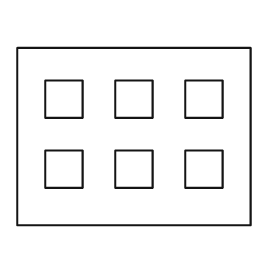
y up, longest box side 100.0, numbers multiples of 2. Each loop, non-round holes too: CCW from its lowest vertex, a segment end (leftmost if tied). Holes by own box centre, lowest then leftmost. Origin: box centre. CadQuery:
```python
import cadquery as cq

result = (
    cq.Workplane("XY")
    .moveTo(-50.0, -38.0)
    .lineTo(50.0, -38.0)
    .lineTo(50.0, 38.0)
    .lineTo(-50.0, 38.0)
    .close()
    .moveTo(-38.0, -22.0)
    .lineTo(-22.0, -22.0)
    .lineTo(-22.0, -6.0)
    .lineTo(-38.0, -6.0)
    .close()
    .moveTo(-8.0, -22.0)
    .lineTo(8.0, -22.0)
    .lineTo(8.0, -6.0)
    .lineTo(-8.0, -6.0)
    .close()
    .moveTo(22.0, -22.0)
    .lineTo(38.0, -22.0)
    .lineTo(38.0, -6.0)
    .lineTo(22.0, -6.0)
    .close()
    .moveTo(-38.0, 8.0)
    .lineTo(-22.0, 8.0)
    .lineTo(-22.0, 24.0)
    .lineTo(-38.0, 24.0)
    .close()
    .moveTo(-8.0, 8.0)
    .lineTo(8.0, 8.0)
    .lineTo(8.0, 24.0)
    .lineTo(-8.0, 24.0)
    .close()
    .moveTo(22.0, 8.0)
    .lineTo(38.0, 8.0)
    .lineTo(38.0, 24.0)
    .lineTo(22.0, 24.0)
    .close()
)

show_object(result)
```